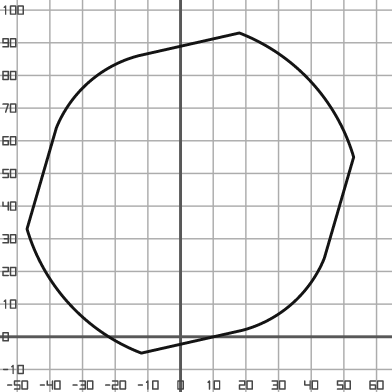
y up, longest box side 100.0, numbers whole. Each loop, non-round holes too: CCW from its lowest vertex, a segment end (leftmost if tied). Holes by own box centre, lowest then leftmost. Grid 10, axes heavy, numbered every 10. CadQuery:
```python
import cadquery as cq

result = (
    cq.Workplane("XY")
    .moveTo(-12.0, -5.0)
    .lineTo(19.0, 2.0)
    .threePointArc((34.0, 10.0), (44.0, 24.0))
    .lineTo(53.0, 55.0)
    .threePointArc((40.0, 78.0), (18.0, 93.0))
    .lineTo(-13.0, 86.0)
    .threePointArc((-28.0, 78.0), (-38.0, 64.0))
    .lineTo(-47.0, 33.0)
    .threePointArc((-34.0, 10.0), (-12.0, -5.0))
    .close()
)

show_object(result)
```